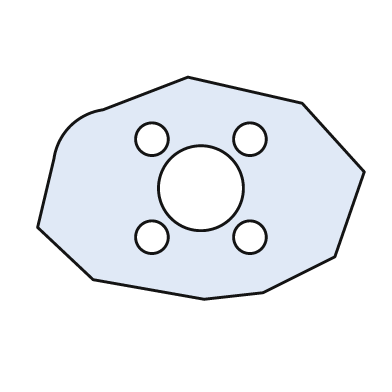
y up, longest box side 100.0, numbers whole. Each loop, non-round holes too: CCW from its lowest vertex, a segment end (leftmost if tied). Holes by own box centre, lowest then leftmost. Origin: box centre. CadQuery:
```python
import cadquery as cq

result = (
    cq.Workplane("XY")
    .moveTo(1.0, -34.0)
    .lineTo(19.0, -32.0)
    .lineTo(41.0, -21.0)
    .lineTo(50.0, 5.0)
    .lineTo(31.0, 26.0)
    .lineTo(-4.0, 34.0)
    .lineTo(-30.0, 24.0)
    .threePointArc((-40.0, 19.0), (-45.0, 9.0))
    .lineTo(-50.0, -12.0)
    .lineTo(-33.0, -28.0)
    .close()
    .moveTo(-15.0, -15.0)
    .circle(5.0)
    .moveTo(15.0, -15.0)
    .circle(5.0)
    .moveTo(0.0, 0.0)
    .circle(13.0)
    .moveTo(-15.0, 15.0)
    .circle(5.0)
    .moveTo(15.0, 15.0)
    .circle(5.0)
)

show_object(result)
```